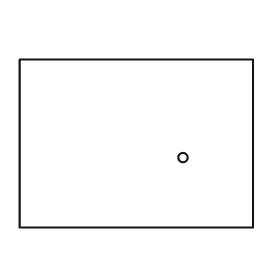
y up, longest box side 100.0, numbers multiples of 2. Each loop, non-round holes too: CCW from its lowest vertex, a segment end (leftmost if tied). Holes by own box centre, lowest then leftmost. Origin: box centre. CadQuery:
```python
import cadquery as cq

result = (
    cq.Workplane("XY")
    .moveTo(-50.0, -36.0)
    .lineTo(50.0, -36.0)
    .lineTo(50.0, 36.0)
    .lineTo(-50.0, 36.0)
    .close()
    .moveTo(20.0, -6.0)
    .circle(2.0)
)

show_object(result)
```